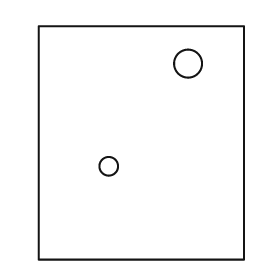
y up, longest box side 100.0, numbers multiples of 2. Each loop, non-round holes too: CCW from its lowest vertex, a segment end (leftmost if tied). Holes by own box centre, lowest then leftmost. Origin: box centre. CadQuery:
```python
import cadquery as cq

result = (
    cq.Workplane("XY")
    .moveTo(-44.0, -50.0)
    .lineTo(44.0, -50.0)
    .lineTo(44.0, 50.0)
    .lineTo(-44.0, 50.0)
    .close()
    .moveTo(-14.0, -10.0)
    .circle(4.0)
    .moveTo(20.0, 34.0)
    .circle(6.0)
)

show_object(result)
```